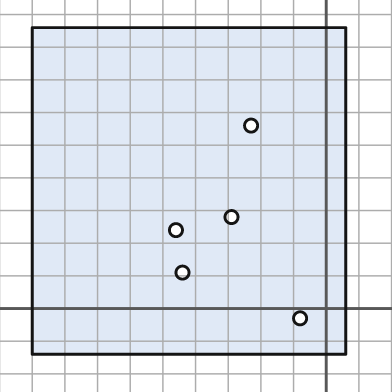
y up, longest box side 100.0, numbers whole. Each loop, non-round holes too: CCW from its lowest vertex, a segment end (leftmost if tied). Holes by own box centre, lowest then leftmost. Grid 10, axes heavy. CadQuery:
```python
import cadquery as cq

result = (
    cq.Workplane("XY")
    .moveTo(-90.0, -14.0)
    .lineTo(6.0, -14.0)
    .lineTo(6.0, 86.0)
    .lineTo(-90.0, 86.0)
    .close()
    .moveTo(-8.0, -3.0)
    .circle(2.0)
    .moveTo(-44.0, 11.0)
    .circle(2.0)
    .moveTo(-46.0, 24.0)
    .circle(2.0)
    .moveTo(-29.0, 28.0)
    .circle(2.0)
    .moveTo(-23.0, 56.0)
    .circle(2.0)
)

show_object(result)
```